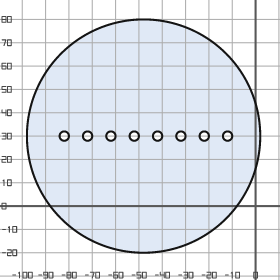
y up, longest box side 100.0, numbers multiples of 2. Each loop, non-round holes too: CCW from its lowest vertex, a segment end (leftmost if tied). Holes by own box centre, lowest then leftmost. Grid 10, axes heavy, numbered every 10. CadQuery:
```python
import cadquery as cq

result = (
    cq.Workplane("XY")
    .moveTo(-48.0, 30.0)
    .circle(50.0)
    .moveTo(-82.0, 30.0)
    .circle(2.0)
    .moveTo(-72.0, 30.0)
    .circle(2.0)
    .moveTo(-62.0, 30.0)
    .circle(2.0)
    .moveTo(-52.0, 30.0)
    .circle(2.0)
    .moveTo(-42.0, 30.0)
    .circle(2.0)
    .moveTo(-32.0, 30.0)
    .circle(2.0)
    .moveTo(-22.0, 30.0)
    .circle(2.0)
    .moveTo(-12.0, 30.0)
    .circle(2.0)
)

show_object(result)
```